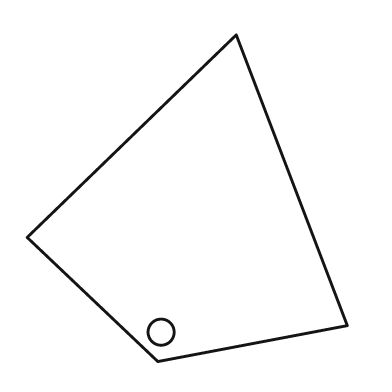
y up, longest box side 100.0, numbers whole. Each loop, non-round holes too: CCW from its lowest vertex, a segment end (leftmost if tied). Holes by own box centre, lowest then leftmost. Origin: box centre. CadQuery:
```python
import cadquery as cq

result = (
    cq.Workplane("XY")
    .moveTo(-9.0, -50.0)
    .lineTo(49.0, -39.0)
    .lineTo(15.0, 50.0)
    .lineTo(-49.0, -12.0)
    .close()
    .moveTo(-8.0, -41.0)
    .circle(4.0)
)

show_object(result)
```